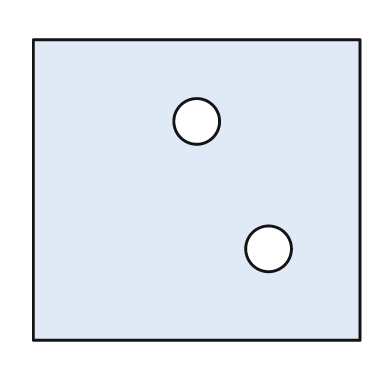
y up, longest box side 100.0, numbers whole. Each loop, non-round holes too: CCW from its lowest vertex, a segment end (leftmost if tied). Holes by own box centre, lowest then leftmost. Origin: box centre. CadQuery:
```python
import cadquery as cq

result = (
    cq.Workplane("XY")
    .moveTo(-50.0, -46.0)
    .lineTo(50.0, -46.0)
    .lineTo(50.0, 46.0)
    .lineTo(-50.0, 46.0)
    .close()
    .moveTo(22.0, -18.0)
    .circle(7.0)
    .moveTo(0.0, 21.0)
    .circle(7.0)
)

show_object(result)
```